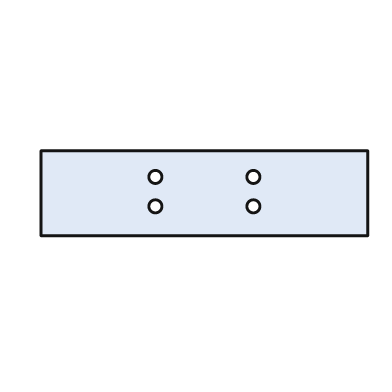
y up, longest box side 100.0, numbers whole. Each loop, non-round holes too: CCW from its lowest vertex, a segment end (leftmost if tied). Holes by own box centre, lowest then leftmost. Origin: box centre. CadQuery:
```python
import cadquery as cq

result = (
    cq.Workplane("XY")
    .moveTo(-50.0, -13.0)
    .lineTo(50.0, -13.0)
    .lineTo(50.0, 13.0)
    .lineTo(-50.0, 13.0)
    .close()
    .moveTo(-15.0, -4.0)
    .circle(2.0)
    .moveTo(15.0, -4.0)
    .circle(2.0)
    .moveTo(-15.0, 5.0)
    .circle(2.0)
    .moveTo(15.0, 5.0)
    .circle(2.0)
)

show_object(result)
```